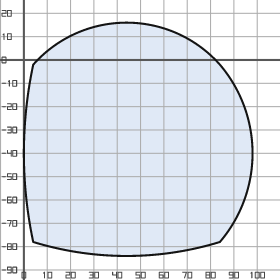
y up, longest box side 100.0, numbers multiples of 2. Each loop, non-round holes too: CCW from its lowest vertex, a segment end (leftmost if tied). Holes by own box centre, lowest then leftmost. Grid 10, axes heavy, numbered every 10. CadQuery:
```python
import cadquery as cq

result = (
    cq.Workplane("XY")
    .moveTo(4.0, -78.0)
    .threePointArc((44.0, -84.0), (84.0, -78.0))
    .threePointArc((98.0, -40.0), (84.0, -2.0))
    .threePointArc((44.0, 16.0), (4.0, -2.0))
    .threePointArc((0.0, -40.0), (4.0, -78.0))
    .close()
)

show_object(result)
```